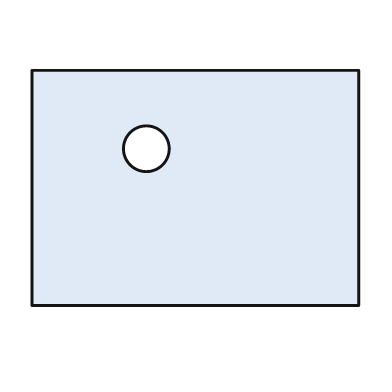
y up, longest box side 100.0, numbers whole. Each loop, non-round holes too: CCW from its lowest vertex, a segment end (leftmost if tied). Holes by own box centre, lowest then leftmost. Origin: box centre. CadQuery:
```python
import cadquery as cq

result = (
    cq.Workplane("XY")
    .moveTo(-50.0, -36.0)
    .lineTo(50.0, -36.0)
    .lineTo(50.0, 36.0)
    .lineTo(-50.0, 36.0)
    .close()
    .moveTo(-15.0, 12.0)
    .circle(7.0)
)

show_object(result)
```